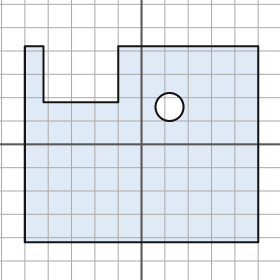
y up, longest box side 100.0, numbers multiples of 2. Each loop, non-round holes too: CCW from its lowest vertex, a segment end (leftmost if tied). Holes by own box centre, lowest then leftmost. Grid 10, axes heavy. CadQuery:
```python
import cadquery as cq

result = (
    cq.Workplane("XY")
    .moveTo(-50.0, -42.0)
    .lineTo(50.0, -42.0)
    .lineTo(50.0, 42.0)
    .lineTo(-10.0, 42.0)
    .lineTo(-10.0, 18.0)
    .lineTo(-42.0, 18.0)
    .lineTo(-42.0, 42.0)
    .lineTo(-50.0, 42.0)
    .close()
    .moveTo(12.0, 16.0)
    .circle(6.0)
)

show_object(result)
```